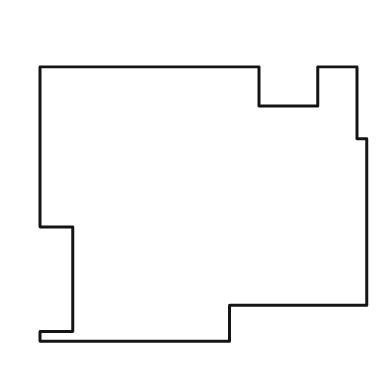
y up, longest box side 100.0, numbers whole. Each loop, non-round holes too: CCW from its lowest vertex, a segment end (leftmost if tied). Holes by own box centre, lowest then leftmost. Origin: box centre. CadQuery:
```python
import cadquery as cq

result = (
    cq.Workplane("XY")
    .moveTo(-50.0, -42.0)
    .lineTo(8.0, -42.0)
    .lineTo(8.0, -31.0)
    .lineTo(50.0, -31.0)
    .lineTo(50.0, 20.0)
    .lineTo(47.0, 20.0)
    .lineTo(47.0, 42.0)
    .lineTo(35.0, 42.0)
    .lineTo(35.0, 30.0)
    .lineTo(17.0, 30.0)
    .lineTo(17.0, 42.0)
    .lineTo(-50.0, 42.0)
    .lineTo(-50.0, -7.0)
    .lineTo(-40.0, -7.0)
    .lineTo(-40.0, -39.0)
    .lineTo(-50.0, -39.0)
    .close()
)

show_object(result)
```